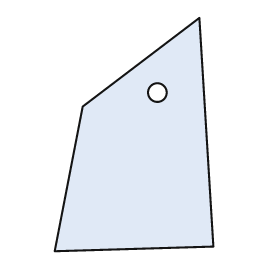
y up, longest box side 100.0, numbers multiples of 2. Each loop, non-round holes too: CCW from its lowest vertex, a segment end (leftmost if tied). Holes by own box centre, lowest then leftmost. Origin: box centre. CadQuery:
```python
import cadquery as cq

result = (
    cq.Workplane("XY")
    .moveTo(-34.0, -50.0)
    .lineTo(34.0, -48.0)
    .lineTo(28.0, 50.0)
    .lineTo(-22.0, 12.0)
    .close()
    .moveTo(10.0, 18.0)
    .circle(4.0)
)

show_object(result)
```